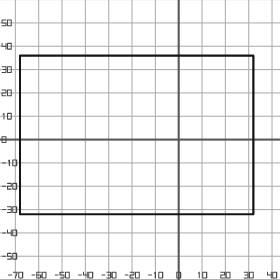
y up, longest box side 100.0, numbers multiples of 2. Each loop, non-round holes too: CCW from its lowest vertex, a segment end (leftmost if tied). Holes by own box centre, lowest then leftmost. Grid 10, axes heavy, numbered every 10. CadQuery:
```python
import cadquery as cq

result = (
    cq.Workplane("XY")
    .moveTo(-68.0, -32.0)
    .lineTo(32.0, -32.0)
    .lineTo(32.0, 36.0)
    .lineTo(-68.0, 36.0)
    .close()
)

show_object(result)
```